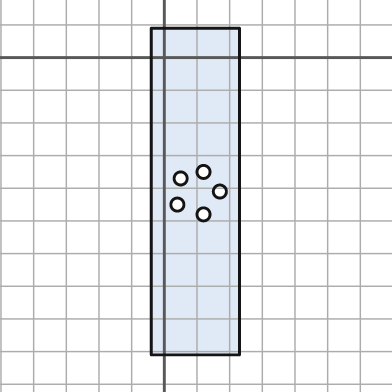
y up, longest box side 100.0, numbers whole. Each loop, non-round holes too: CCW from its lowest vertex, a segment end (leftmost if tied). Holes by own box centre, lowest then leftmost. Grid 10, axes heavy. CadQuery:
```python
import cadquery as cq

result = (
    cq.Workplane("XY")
    .moveTo(-4.0, -91.0)
    .lineTo(23.0, -91.0)
    .lineTo(23.0, 9.0)
    .lineTo(-4.0, 9.0)
    .close()
    .moveTo(12.0, -48.0)
    .circle(2.0)
    .moveTo(4.0, -45.0)
    .circle(2.0)
    .moveTo(17.0, -41.0)
    .circle(2.0)
    .moveTo(5.0, -37.0)
    .circle(2.0)
    .moveTo(12.0, -35.0)
    .circle(2.0)
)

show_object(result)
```